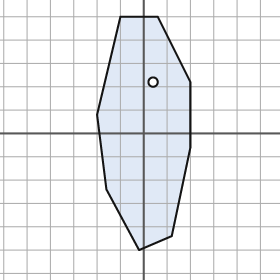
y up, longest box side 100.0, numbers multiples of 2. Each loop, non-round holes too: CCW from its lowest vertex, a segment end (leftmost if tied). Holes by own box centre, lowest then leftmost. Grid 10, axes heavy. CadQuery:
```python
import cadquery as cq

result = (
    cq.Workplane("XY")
    .moveTo(-2.0, -50.0)
    .lineTo(12.0, -44.0)
    .lineTo(20.0, -6.0)
    .lineTo(20.0, 22.0)
    .lineTo(6.0, 50.0)
    .lineTo(-10.0, 50.0)
    .lineTo(-20.0, 8.0)
    .lineTo(-16.0, -24.0)
    .close()
    .moveTo(4.0, 22.0)
    .circle(2.0)
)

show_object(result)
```